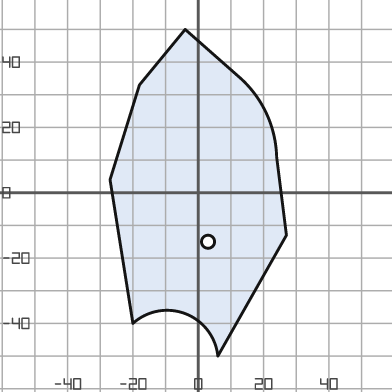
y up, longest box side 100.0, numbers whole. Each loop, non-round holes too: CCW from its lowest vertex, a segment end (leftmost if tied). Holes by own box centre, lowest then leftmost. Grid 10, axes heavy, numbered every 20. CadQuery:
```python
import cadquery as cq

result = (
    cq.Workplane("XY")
    .moveTo(6.0, -50.0)
    .lineTo(27.0, -13.0)
    .lineTo(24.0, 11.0)
    .threePointArc((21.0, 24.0), (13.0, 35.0))
    .lineTo(-4.0, 50.0)
    .lineTo(-18.0, 33.0)
    .lineTo(-27.0, 4.0)
    .lineTo(-20.0, -40.0)
    .threePointArc((-4.0, -37.0), (6.0, -50.0))
    .close()
    .moveTo(3.0, -15.0)
    .circle(2.0)
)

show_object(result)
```